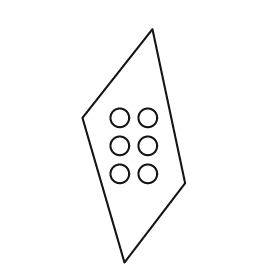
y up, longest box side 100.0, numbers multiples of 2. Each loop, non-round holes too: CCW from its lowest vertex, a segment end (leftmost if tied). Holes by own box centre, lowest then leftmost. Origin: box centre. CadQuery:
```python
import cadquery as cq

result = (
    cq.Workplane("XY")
    .moveTo(-4.0, -50.0)
    .lineTo(22.0, -16.0)
    .lineTo(8.0, 50.0)
    .lineTo(-22.0, 12.0)
    .close()
    .moveTo(-6.0, -12.0)
    .circle(4.0)
    .moveTo(6.0, -12.0)
    .circle(4.0)
    .moveTo(-6.0, 0.0)
    .circle(4.0)
    .moveTo(6.0, 0.0)
    .circle(4.0)
    .moveTo(-6.0, 12.0)
    .circle(4.0)
    .moveTo(6.0, 12.0)
    .circle(4.0)
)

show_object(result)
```